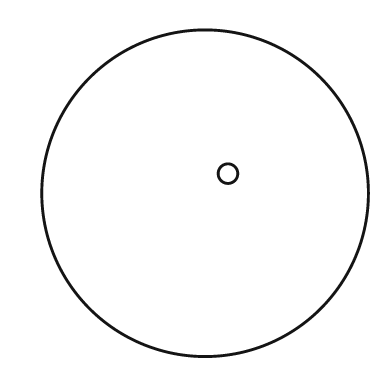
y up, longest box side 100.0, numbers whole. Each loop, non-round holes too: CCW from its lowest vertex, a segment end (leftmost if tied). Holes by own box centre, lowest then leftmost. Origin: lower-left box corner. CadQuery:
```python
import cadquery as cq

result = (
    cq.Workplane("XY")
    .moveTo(50.0, 50.0)
    .circle(50.0)
    .moveTo(57.0, 56.0)
    .circle(3.0)
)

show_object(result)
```